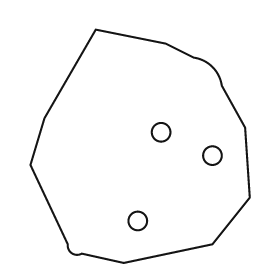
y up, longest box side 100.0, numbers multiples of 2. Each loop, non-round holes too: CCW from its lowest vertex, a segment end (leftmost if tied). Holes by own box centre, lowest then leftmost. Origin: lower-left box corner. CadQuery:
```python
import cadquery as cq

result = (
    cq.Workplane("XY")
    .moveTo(40.0, 0.0)
    .lineTo(78.0, 8.0)
    .lineTo(94.0, 28.0)
    .lineTo(92.0, 58.0)
    .lineTo(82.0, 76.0)
    .threePointArc((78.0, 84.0), (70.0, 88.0))
    .lineTo(58.0, 94.0)
    .lineTo(28.0, 100.0)
    .lineTo(6.0, 62.0)
    .lineTo(0.0, 42.0)
    .lineTo(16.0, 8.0)
    .threePointArc((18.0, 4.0), (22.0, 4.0))
    .close()
    .moveTo(46.0, 18.0)
    .circle(4.0)
    .moveTo(78.0, 46.0)
    .circle(4.0)
    .moveTo(56.0, 56.0)
    .circle(4.0)
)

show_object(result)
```